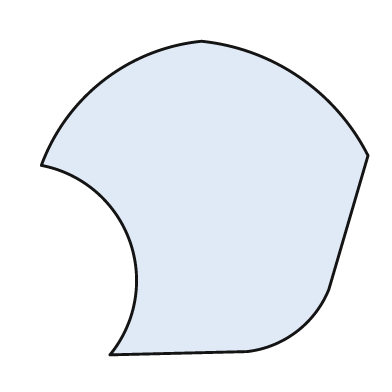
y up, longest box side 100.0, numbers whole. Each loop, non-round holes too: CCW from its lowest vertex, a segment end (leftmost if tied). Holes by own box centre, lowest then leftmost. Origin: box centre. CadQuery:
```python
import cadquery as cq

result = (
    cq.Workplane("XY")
    .moveTo(-29.0, -48.0)
    .lineTo(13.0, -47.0)
    .threePointArc((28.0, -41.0), (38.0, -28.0))
    .lineTo(50.0, 13.0)
    .threePointArc((29.0, 37.0), (-1.0, 48.0))
    .threePointArc((-31.0, 36.0), (-50.0, 10.0))
    .threePointArc((-23.0, -13.0), (-29.0, -48.0))
    .close()
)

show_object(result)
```